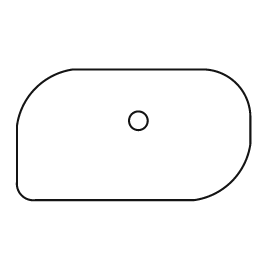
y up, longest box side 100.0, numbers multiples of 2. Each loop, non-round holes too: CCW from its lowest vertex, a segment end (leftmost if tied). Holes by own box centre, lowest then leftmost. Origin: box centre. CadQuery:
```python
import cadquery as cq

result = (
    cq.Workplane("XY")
    .moveTo(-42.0, -28.0)
    .lineTo(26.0, -28.0)
    .threePointArc((42.0, -20.0), (50.0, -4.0))
    .lineTo(50.0, 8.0)
    .threePointArc((44.0, 22.0), (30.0, 28.0))
    .lineTo(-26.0, 28.0)
    .threePointArc((-42.0, 20.0), (-50.0, 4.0))
    .lineTo(-50.0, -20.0)
    .threePointArc((-48.0, -26.0), (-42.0, -28.0))
    .close()
    .moveTo(2.0, 6.0)
    .circle(4.0)
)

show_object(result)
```